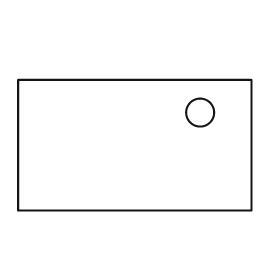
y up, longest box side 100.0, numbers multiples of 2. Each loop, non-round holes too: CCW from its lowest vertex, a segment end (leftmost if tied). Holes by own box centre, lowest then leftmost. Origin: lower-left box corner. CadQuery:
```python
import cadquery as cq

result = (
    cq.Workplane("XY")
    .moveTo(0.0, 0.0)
    .lineTo(100.0, 0.0)
    .lineTo(100.0, 56.0)
    .lineTo(0.0, 56.0)
    .close()
    .moveTo(78.0, 42.0)
    .circle(6.0)
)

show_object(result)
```